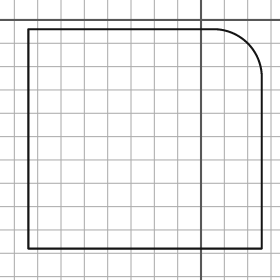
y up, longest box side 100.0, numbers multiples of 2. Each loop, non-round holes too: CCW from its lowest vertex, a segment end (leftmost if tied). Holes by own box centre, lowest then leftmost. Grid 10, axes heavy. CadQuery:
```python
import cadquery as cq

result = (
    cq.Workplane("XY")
    .moveTo(-74.0, -98.0)
    .lineTo(26.0, -98.0)
    .lineTo(26.0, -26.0)
    .threePointArc((20.0, -10.0), (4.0, -4.0))
    .lineTo(-74.0, -4.0)
    .close()
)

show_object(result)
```